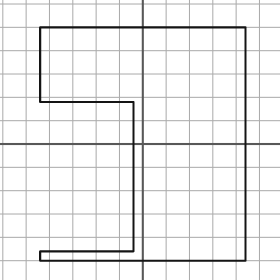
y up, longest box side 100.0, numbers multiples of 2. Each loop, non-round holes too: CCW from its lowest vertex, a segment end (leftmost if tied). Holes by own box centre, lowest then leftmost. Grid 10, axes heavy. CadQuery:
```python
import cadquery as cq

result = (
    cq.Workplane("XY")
    .moveTo(-44.0, -50.0)
    .lineTo(44.0, -50.0)
    .lineTo(44.0, 50.0)
    .lineTo(-44.0, 50.0)
    .lineTo(-44.0, 18.0)
    .lineTo(-4.0, 18.0)
    .lineTo(-4.0, -46.0)
    .lineTo(-44.0, -46.0)
    .close()
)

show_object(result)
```